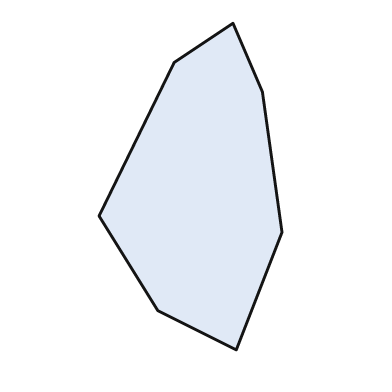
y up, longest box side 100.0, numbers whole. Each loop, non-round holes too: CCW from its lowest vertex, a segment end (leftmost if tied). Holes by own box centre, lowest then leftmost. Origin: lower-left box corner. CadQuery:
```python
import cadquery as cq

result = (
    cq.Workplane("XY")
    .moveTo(42.0, 0.0)
    .lineTo(56.0, 36.0)
    .lineTo(50.0, 79.0)
    .lineTo(41.0, 100.0)
    .lineTo(23.0, 88.0)
    .lineTo(0.0, 41.0)
    .lineTo(18.0, 12.0)
    .close()
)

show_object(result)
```